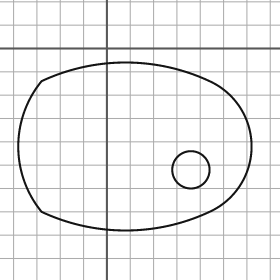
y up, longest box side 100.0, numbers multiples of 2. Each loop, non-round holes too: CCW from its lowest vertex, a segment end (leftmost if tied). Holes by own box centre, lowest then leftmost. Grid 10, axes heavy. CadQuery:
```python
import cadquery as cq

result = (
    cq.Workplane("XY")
    .moveTo(-28.0, -70.0)
    .threePointArc((8.0, -78.0), (44.0, -70.0))
    .threePointArc((62.0, -42.0), (44.0, -14.0))
    .threePointArc((8.0, -6.0), (-28.0, -14.0))
    .threePointArc((-38.0, -42.0), (-28.0, -70.0))
    .close()
    .moveTo(36.0, -52.0)
    .circle(8.0)
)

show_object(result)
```